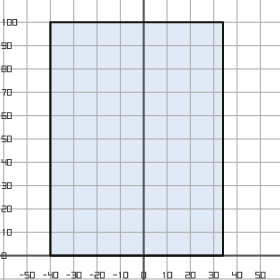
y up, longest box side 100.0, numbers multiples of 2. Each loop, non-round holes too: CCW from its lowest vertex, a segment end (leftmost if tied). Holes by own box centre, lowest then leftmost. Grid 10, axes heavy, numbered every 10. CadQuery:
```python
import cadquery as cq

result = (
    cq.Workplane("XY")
    .moveTo(-40.0, 0.0)
    .lineTo(34.0, 0.0)
    .lineTo(34.0, 100.0)
    .lineTo(-40.0, 100.0)
    .close()
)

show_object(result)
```